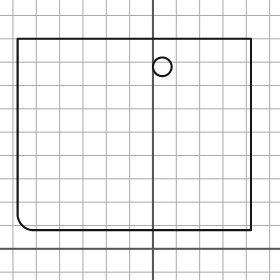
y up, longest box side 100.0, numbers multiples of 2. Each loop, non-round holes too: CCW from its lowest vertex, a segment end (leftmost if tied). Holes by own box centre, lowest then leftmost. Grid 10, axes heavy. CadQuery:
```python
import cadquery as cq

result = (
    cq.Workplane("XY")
    .moveTo(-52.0, 8.0)
    .lineTo(42.0, 8.0)
    .lineTo(42.0, 90.0)
    .lineTo(-58.0, 90.0)
    .lineTo(-58.0, 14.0)
    .threePointArc((-56.0, 10.0), (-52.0, 8.0))
    .close()
    .moveTo(4.0, 78.0)
    .circle(4.0)
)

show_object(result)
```